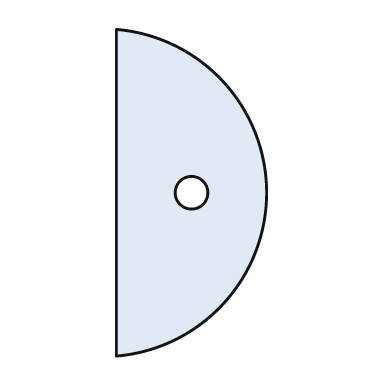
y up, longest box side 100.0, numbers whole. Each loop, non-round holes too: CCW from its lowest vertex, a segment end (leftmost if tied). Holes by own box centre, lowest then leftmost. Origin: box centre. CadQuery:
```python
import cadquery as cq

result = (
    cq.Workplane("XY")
    .moveTo(-23.0, -50.0)
    .threePointArc((23.0, 0.0), (-23.0, 50.0))
    .close()
    .moveTo(0.0, 0.0)
    .circle(5.0)
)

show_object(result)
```